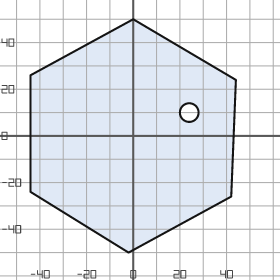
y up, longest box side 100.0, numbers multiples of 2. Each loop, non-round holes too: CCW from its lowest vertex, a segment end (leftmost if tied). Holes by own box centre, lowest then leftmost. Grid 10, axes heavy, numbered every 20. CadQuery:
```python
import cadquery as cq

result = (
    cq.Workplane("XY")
    .moveTo(-2.0, -50.0)
    .lineTo(42.0, -26.0)
    .lineTo(44.0, 24.0)
    .lineTo(0.0, 50.0)
    .lineTo(-44.0, 26.0)
    .lineTo(-44.0, -24.0)
    .close()
    .moveTo(24.0, 10.0)
    .circle(4.0)
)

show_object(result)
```